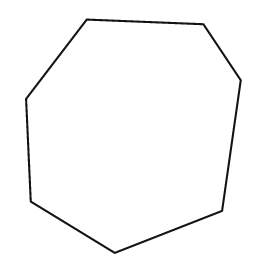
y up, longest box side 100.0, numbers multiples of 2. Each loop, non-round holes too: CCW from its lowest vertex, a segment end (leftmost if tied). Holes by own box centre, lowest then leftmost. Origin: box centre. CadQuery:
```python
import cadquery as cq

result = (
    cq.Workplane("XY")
    .moveTo(-8.0, -50.0)
    .lineTo(38.0, -32.0)
    .lineTo(46.0, 24.0)
    .lineTo(30.0, 48.0)
    .lineTo(-20.0, 50.0)
    .lineTo(-46.0, 16.0)
    .lineTo(-44.0, -28.0)
    .close()
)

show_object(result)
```